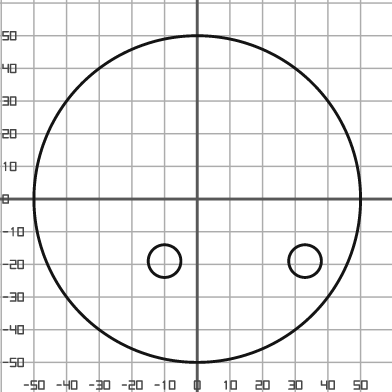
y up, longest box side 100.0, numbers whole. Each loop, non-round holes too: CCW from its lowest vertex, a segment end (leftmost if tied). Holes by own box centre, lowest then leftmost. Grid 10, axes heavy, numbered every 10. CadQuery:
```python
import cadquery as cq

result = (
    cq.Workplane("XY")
    .moveTo(0.0, 0.0)
    .circle(50.0)
    .moveTo(-10.0, -19.0)
    .circle(5.0)
    .moveTo(33.0, -19.0)
    .circle(5.0)
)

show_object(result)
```